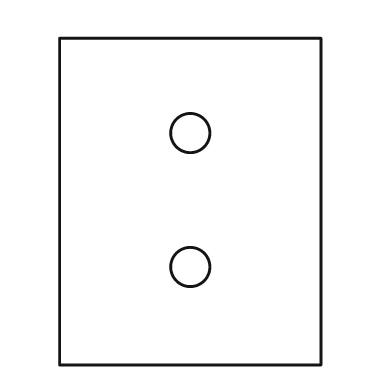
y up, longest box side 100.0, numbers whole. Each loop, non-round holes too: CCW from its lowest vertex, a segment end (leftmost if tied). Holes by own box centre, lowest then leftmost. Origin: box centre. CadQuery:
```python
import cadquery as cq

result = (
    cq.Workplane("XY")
    .moveTo(-40.0, -50.0)
    .lineTo(40.0, -50.0)
    .lineTo(40.0, 50.0)
    .lineTo(-40.0, 50.0)
    .close()
    .moveTo(0.0, -20.0)
    .circle(6.0)
    .moveTo(0.0, 21.0)
    .circle(6.0)
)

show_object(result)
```